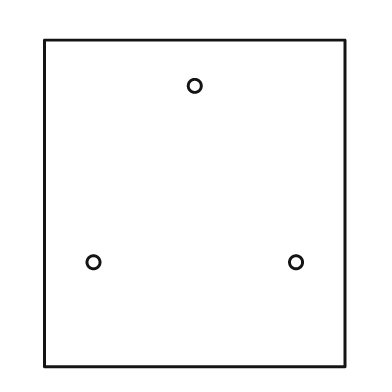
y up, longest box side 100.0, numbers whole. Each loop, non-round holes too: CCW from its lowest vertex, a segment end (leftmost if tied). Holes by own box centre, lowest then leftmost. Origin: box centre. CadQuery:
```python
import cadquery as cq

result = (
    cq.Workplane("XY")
    .moveTo(-46.0, -50.0)
    .lineTo(46.0, -50.0)
    .lineTo(46.0, 50.0)
    .lineTo(-46.0, 50.0)
    .close()
    .moveTo(-31.0, -18.0)
    .circle(2.0)
    .moveTo(31.0, -18.0)
    .circle(2.0)
    .moveTo(0.0, 36.0)
    .circle(2.0)
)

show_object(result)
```